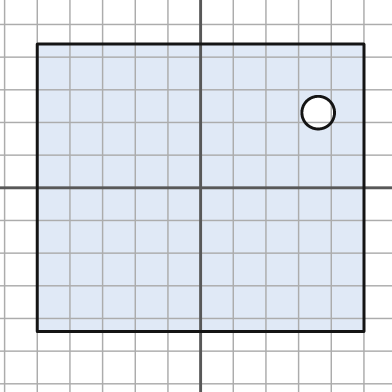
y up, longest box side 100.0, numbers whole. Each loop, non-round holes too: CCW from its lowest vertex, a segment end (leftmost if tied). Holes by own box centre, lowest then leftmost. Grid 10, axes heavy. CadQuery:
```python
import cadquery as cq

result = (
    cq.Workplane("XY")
    .moveTo(-50.0, -44.0)
    .lineTo(50.0, -44.0)
    .lineTo(50.0, 44.0)
    .lineTo(-50.0, 44.0)
    .close()
    .moveTo(36.0, 23.0)
    .circle(5.0)
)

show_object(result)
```